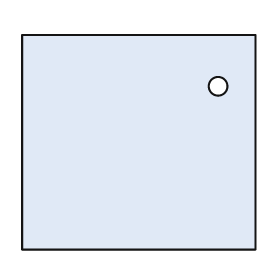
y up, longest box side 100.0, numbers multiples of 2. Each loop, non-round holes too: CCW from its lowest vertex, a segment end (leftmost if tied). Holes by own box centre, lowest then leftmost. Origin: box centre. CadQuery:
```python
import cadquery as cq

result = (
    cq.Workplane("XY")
    .moveTo(-50.0, -46.0)
    .lineTo(50.0, -46.0)
    .lineTo(50.0, 46.0)
    .lineTo(-50.0, 46.0)
    .close()
    .moveTo(34.0, 24.0)
    .circle(4.0)
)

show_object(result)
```